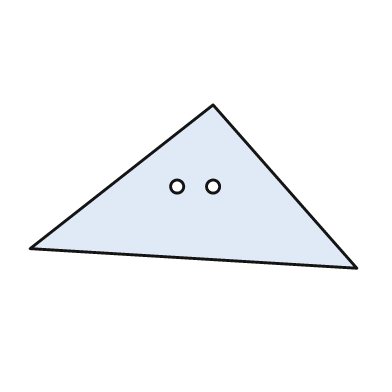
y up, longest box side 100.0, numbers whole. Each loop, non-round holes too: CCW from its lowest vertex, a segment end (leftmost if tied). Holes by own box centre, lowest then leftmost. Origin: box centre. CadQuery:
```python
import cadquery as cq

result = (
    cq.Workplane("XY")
    .moveTo(50.0, -25.0)
    .lineTo(6.0, 25.0)
    .lineTo(-50.0, -19.0)
    .close()
    .moveTo(-5.0, 0.0)
    .circle(2.0)
    .moveTo(6.0, 0.0)
    .circle(2.0)
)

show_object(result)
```